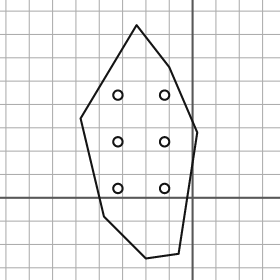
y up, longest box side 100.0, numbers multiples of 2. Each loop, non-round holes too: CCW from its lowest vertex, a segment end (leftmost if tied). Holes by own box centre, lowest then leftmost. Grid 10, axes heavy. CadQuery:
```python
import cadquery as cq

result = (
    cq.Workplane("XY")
    .moveTo(-20.0, -26.0)
    .lineTo(-6.0, -24.0)
    .lineTo(2.0, 28.0)
    .lineTo(-10.0, 56.0)
    .lineTo(-24.0, 74.0)
    .lineTo(-48.0, 34.0)
    .lineTo(-38.0, -8.0)
    .close()
    .moveTo(-32.0, 4.0)
    .circle(2.0)
    .moveTo(-12.0, 4.0)
    .circle(2.0)
    .moveTo(-32.0, 24.0)
    .circle(2.0)
    .moveTo(-12.0, 24.0)
    .circle(2.0)
    .moveTo(-32.0, 44.0)
    .circle(2.0)
    .moveTo(-12.0, 44.0)
    .circle(2.0)
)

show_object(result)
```